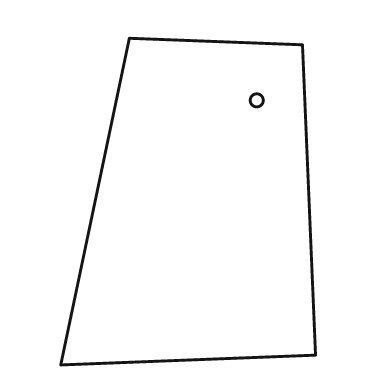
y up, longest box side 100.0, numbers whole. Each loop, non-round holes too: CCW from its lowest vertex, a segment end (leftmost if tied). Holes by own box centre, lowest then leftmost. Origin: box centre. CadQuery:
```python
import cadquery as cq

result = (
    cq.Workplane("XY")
    .moveTo(-39.0, -50.0)
    .lineTo(39.0, -47.0)
    .lineTo(35.0, 48.0)
    .lineTo(-18.0, 50.0)
    .close()
    .moveTo(21.0, 31.0)
    .circle(2.0)
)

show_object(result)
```